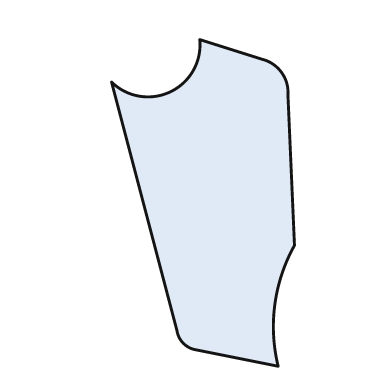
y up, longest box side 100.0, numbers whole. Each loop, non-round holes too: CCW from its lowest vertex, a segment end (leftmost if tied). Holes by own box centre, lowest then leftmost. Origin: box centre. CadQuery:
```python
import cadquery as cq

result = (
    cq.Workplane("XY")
    .moveTo(23.0, -50.0)
    .threePointArc((22.0, -31.0), (28.0, -13.0))
    .lineTo(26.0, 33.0)
    .threePointArc((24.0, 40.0), (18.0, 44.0))
    .lineTo(-1.0, 50.0)
    .threePointArc((-10.0, 34.0), (-28.0, 37.0))
    .lineTo(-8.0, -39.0)
    .threePointArc((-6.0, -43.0), (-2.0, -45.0))
    .close()
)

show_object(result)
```